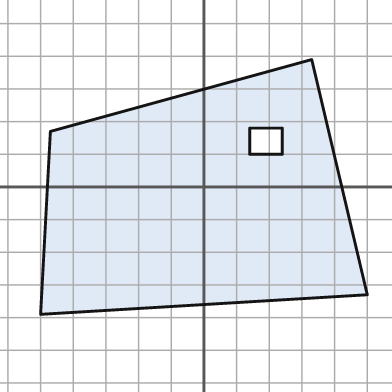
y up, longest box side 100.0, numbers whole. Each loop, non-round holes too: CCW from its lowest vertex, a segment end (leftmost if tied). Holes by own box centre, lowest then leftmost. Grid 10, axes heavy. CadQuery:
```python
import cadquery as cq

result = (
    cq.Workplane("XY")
    .moveTo(-50.0, -39.0)
    .lineTo(50.0, -33.0)
    .lineTo(33.0, 39.0)
    .lineTo(-47.0, 17.0)
    .close()
    .moveTo(14.0, 10.0)
    .lineTo(24.0, 10.0)
    .lineTo(24.0, 18.0)
    .lineTo(14.0, 18.0)
    .close()
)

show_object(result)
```